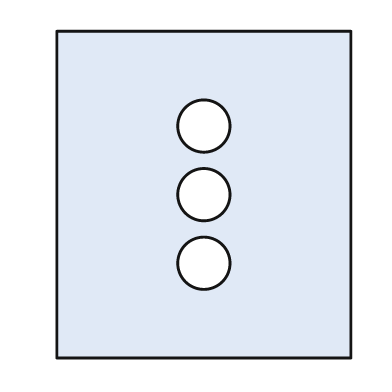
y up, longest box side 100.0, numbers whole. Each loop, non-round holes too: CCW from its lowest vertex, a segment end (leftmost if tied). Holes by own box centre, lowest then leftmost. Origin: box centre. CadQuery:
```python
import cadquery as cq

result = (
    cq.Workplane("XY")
    .moveTo(-45.0, -50.0)
    .lineTo(45.0, -50.0)
    .lineTo(45.0, 50.0)
    .lineTo(-45.0, 50.0)
    .close()
    .moveTo(0.0, -21.0)
    .circle(8.0)
    .moveTo(0.0, 0.0)
    .circle(8.0)
    .moveTo(0.0, 21.0)
    .circle(8.0)
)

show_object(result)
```